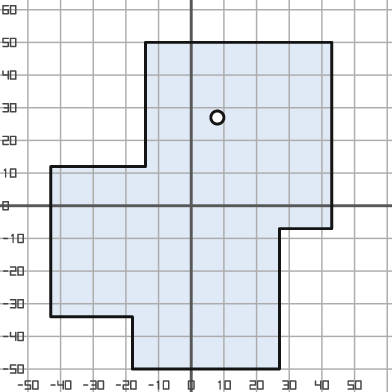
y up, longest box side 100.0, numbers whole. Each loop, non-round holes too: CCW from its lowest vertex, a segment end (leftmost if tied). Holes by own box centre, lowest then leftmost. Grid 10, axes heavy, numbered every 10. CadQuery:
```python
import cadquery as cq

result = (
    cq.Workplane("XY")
    .moveTo(-18.0, -50.0)
    .lineTo(27.0, -50.0)
    .lineTo(27.0, -7.0)
    .lineTo(43.0, -7.0)
    .lineTo(43.0, 50.0)
    .lineTo(-14.0, 50.0)
    .lineTo(-14.0, 12.0)
    .lineTo(-43.0, 12.0)
    .lineTo(-43.0, -34.0)
    .lineTo(-18.0, -34.0)
    .close()
    .moveTo(8.0, 27.0)
    .circle(2.0)
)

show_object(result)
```